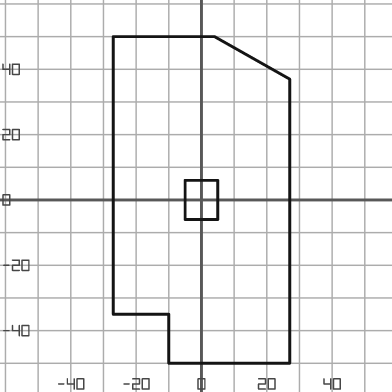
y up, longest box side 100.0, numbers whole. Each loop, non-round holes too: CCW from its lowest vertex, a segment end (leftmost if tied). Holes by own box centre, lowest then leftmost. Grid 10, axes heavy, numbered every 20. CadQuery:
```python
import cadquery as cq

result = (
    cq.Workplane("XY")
    .moveTo(-10.0, -50.0)
    .lineTo(27.0, -50.0)
    .lineTo(27.0, 37.0)
    .lineTo(4.0, 50.0)
    .lineTo(-27.0, 50.0)
    .lineTo(-27.0, -35.0)
    .lineTo(-10.0, -35.0)
    .close()
    .moveTo(-5.0, -6.0)
    .lineTo(5.0, -6.0)
    .lineTo(5.0, 6.0)
    .lineTo(-5.0, 6.0)
    .close()
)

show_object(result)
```